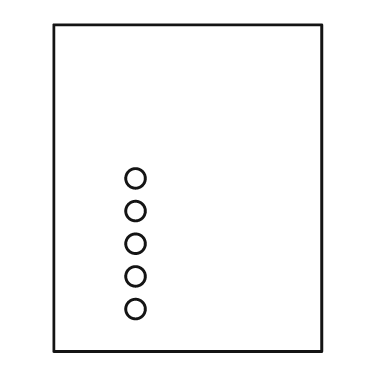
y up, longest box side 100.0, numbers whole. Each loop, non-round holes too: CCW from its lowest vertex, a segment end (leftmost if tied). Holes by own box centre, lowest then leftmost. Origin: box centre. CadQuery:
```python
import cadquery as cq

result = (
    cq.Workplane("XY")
    .moveTo(-41.0, -50.0)
    .lineTo(41.0, -50.0)
    .lineTo(41.0, 50.0)
    .lineTo(-41.0, 50.0)
    .close()
    .moveTo(-16.0, -37.0)
    .circle(3.0)
    .moveTo(-16.0, -27.0)
    .circle(3.0)
    .moveTo(-16.0, -17.0)
    .circle(3.0)
    .moveTo(-16.0, -7.0)
    .circle(3.0)
    .moveTo(-16.0, 3.0)
    .circle(3.0)
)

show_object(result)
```